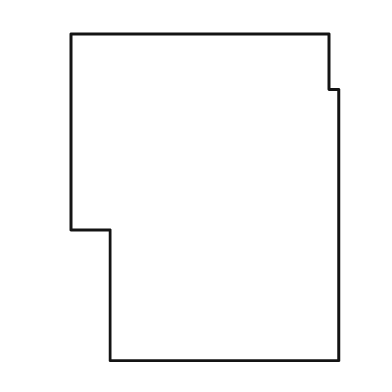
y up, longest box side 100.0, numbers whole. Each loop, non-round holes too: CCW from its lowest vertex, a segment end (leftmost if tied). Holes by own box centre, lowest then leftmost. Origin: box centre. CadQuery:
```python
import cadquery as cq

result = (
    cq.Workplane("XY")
    .moveTo(-29.0, -50.0)
    .lineTo(41.0, -50.0)
    .lineTo(41.0, 33.0)
    .lineTo(38.0, 33.0)
    .lineTo(38.0, 50.0)
    .lineTo(-41.0, 50.0)
    .lineTo(-41.0, -10.0)
    .lineTo(-29.0, -10.0)
    .close()
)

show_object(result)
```